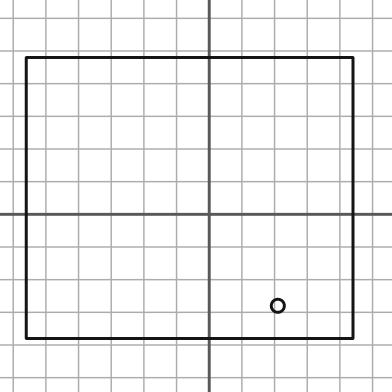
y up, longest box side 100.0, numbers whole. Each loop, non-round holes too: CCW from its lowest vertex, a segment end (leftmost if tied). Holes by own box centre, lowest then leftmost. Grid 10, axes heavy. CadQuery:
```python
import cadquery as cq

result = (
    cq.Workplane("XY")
    .moveTo(-56.0, -38.0)
    .lineTo(44.0, -38.0)
    .lineTo(44.0, 48.0)
    .lineTo(-56.0, 48.0)
    .close()
    .moveTo(21.0, -28.0)
    .circle(2.0)
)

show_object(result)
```